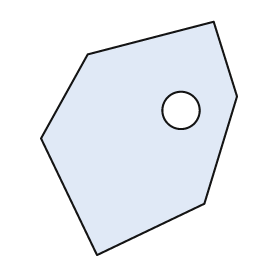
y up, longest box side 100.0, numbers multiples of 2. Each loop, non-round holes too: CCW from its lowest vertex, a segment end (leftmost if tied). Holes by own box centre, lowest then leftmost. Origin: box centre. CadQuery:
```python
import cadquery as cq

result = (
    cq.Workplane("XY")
    .moveTo(-18.0, -50.0)
    .lineTo(28.0, -28.0)
    .lineTo(42.0, 18.0)
    .lineTo(32.0, 50.0)
    .lineTo(-22.0, 36.0)
    .lineTo(-42.0, 0.0)
    .close()
    .moveTo(18.0, 12.0)
    .circle(8.0)
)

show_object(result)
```